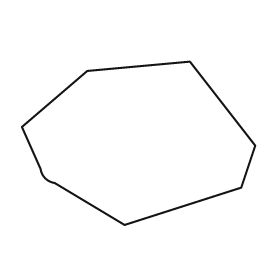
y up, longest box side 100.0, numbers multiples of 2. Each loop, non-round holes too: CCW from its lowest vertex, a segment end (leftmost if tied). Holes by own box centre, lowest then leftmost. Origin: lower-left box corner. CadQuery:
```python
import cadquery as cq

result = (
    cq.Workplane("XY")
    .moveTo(44.0, 0.0)
    .lineTo(94.0, 16.0)
    .lineTo(100.0, 34.0)
    .lineTo(72.0, 70.0)
    .lineTo(28.0, 66.0)
    .lineTo(0.0, 42.0)
    .lineTo(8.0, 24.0)
    .threePointArc((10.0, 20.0), (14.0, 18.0))
    .close()
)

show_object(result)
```